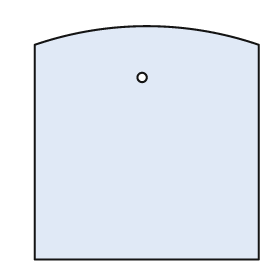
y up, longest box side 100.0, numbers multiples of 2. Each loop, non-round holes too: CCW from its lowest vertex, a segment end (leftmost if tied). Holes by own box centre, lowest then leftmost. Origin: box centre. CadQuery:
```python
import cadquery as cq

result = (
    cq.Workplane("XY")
    .moveTo(-48.0, -50.0)
    .lineTo(48.0, -50.0)
    .lineTo(48.0, 42.0)
    .threePointArc((0.0, 50.0), (-48.0, 42.0))
    .close()
    .moveTo(-2.0, 28.0)
    .circle(2.0)
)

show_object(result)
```